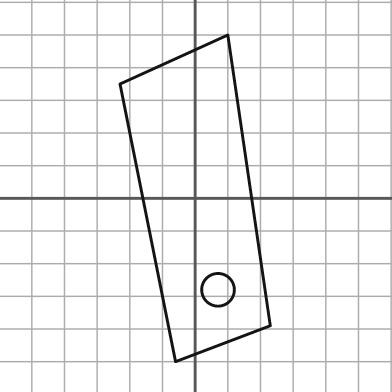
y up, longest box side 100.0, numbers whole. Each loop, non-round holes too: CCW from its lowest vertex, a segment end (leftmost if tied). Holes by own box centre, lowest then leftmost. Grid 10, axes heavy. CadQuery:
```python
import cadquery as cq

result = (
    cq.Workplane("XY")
    .moveTo(-6.0, -50.0)
    .lineTo(23.0, -39.0)
    .lineTo(10.0, 50.0)
    .lineTo(-23.0, 35.0)
    .close()
    .moveTo(7.0, -28.0)
    .circle(5.0)
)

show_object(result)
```